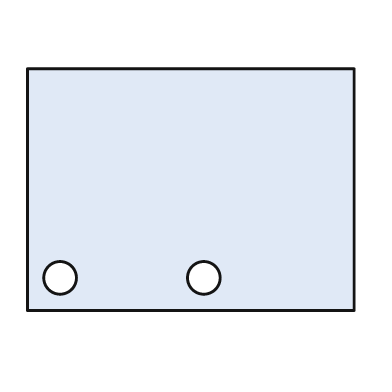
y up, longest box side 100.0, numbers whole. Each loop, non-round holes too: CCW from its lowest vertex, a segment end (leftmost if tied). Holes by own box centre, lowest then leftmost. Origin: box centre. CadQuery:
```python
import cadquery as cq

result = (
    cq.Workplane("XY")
    .moveTo(-50.0, -37.0)
    .lineTo(50.0, -37.0)
    .lineTo(50.0, 37.0)
    .lineTo(-50.0, 37.0)
    .close()
    .moveTo(-40.0, -27.0)
    .circle(5.0)
    .moveTo(4.0, -27.0)
    .circle(5.0)
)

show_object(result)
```